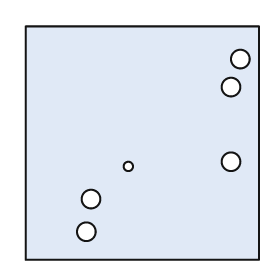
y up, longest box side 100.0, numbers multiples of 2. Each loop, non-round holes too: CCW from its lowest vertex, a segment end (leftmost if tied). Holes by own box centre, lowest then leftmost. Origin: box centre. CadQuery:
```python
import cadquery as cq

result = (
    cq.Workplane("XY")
    .moveTo(-50.0, -50.0)
    .lineTo(50.0, -50.0)
    .lineTo(50.0, 50.0)
    .lineTo(-50.0, 50.0)
    .close()
    .moveTo(-24.0, -38.0)
    .circle(4.0)
    .moveTo(-22.0, -24.0)
    .circle(4.0)
    .moveTo(-6.0, -10.0)
    .circle(2.0)
    .moveTo(38.0, -8.0)
    .circle(4.0)
    .moveTo(38.0, 24.0)
    .circle(4.0)
    .moveTo(42.0, 36.0)
    .circle(4.0)
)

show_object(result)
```